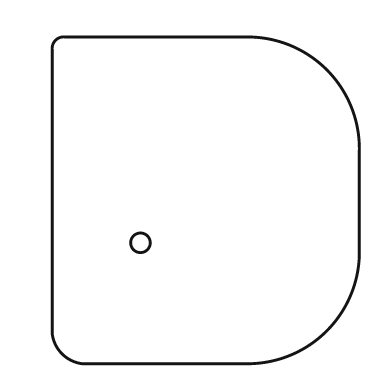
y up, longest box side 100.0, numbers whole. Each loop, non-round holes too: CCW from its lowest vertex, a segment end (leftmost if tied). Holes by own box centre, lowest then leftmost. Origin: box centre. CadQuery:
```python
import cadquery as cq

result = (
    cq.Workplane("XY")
    .moveTo(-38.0, -50.0)
    .lineTo(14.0, -50.0)
    .threePointArc((37.0, -40.0), (47.0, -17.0))
    .lineTo(47.0, 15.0)
    .threePointArc((37.0, 40.0), (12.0, 50.0))
    .lineTo(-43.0, 50.0)
    .threePointArc((-46.0, 49.0), (-47.0, 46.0))
    .lineTo(-47.0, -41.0)
    .threePointArc((-44.0, -47.0), (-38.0, -50.0))
    .close()
    .moveTo(-20.0, -13.0)
    .circle(3.0)
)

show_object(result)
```